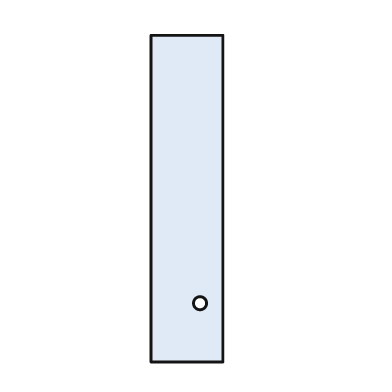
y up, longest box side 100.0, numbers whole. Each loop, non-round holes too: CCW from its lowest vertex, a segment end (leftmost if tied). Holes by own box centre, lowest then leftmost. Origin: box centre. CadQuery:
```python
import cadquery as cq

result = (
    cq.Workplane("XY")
    .moveTo(-11.0, -50.0)
    .lineTo(11.0, -50.0)
    .lineTo(11.0, 50.0)
    .lineTo(-11.0, 50.0)
    .close()
    .moveTo(4.0, -32.0)
    .circle(2.0)
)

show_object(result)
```